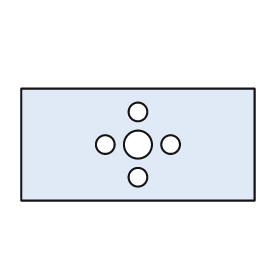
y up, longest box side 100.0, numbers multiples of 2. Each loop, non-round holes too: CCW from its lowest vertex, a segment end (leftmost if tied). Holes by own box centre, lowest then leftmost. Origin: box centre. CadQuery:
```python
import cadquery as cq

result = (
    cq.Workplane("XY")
    .moveTo(-50.0, -24.0)
    .lineTo(50.0, -24.0)
    .lineTo(50.0, 24.0)
    .lineTo(-50.0, 24.0)
    .close()
    .moveTo(0.0, -14.0)
    .circle(4.0)
    .moveTo(-14.0, 0.0)
    .circle(4.0)
    .moveTo(0.0, 0.0)
    .circle(6.0)
    .moveTo(14.0, 0.0)
    .circle(4.0)
    .moveTo(0.0, 14.0)
    .circle(4.0)
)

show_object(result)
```